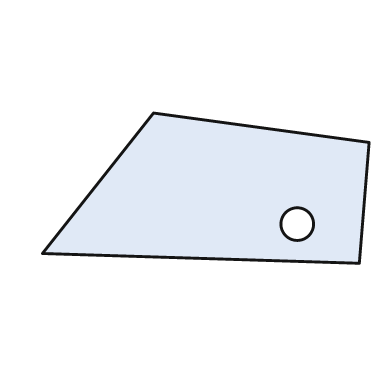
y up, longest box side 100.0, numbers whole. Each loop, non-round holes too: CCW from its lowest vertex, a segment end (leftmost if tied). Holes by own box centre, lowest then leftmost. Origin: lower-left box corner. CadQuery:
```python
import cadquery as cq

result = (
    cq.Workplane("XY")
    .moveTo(97.0, 0.0)
    .lineTo(100.0, 37.0)
    .lineTo(34.0, 46.0)
    .lineTo(0.0, 3.0)
    .close()
    .moveTo(78.0, 12.0)
    .circle(5.0)
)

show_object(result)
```